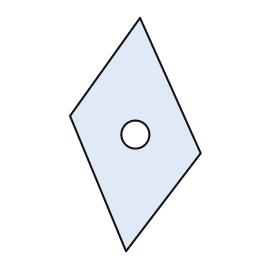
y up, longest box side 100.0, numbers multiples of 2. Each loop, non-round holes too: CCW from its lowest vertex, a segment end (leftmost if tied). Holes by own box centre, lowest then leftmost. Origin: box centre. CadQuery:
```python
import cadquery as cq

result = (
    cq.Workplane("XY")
    .moveTo(-4.0, -50.0)
    .lineTo(28.0, -8.0)
    .lineTo(2.0, 50.0)
    .lineTo(-28.0, 8.0)
    .close()
    .moveTo(0.0, 0.0)
    .circle(6.0)
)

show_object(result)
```